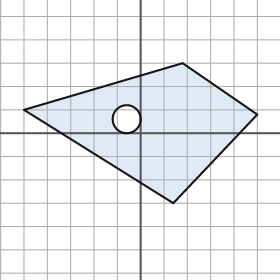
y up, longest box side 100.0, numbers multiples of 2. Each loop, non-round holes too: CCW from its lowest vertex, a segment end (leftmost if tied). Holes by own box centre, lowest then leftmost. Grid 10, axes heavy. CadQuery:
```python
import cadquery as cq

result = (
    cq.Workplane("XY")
    .moveTo(14.0, -30.0)
    .lineTo(50.0, 8.0)
    .lineTo(18.0, 30.0)
    .lineTo(-50.0, 10.0)
    .close()
    .moveTo(-6.0, 6.0)
    .circle(6.0)
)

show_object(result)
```